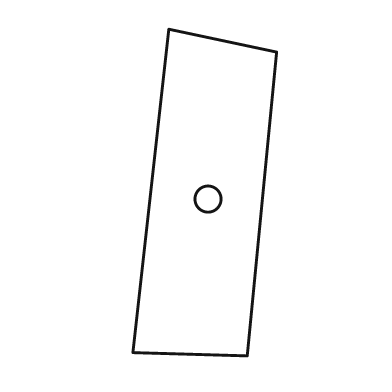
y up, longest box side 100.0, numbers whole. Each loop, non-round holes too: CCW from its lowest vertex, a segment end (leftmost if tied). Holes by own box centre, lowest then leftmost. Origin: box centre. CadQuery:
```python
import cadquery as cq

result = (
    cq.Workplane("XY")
    .moveTo(13.0, -50.0)
    .lineTo(22.0, 43.0)
    .lineTo(-11.0, 50.0)
    .lineTo(-22.0, -49.0)
    .close()
    .moveTo(1.0, -2.0)
    .circle(4.0)
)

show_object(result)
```